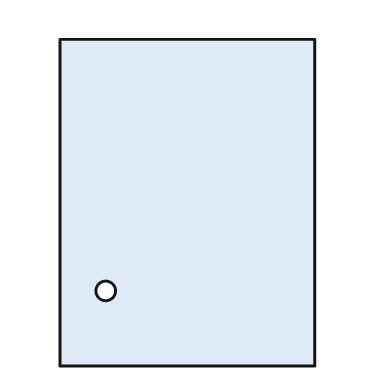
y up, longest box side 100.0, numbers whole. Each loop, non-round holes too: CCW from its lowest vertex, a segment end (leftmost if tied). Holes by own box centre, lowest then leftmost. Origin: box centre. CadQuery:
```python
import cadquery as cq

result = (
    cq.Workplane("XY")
    .moveTo(-39.0, -50.0)
    .lineTo(39.0, -50.0)
    .lineTo(39.0, 50.0)
    .lineTo(-39.0, 50.0)
    .close()
    .moveTo(-25.0, -27.0)
    .circle(3.0)
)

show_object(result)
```